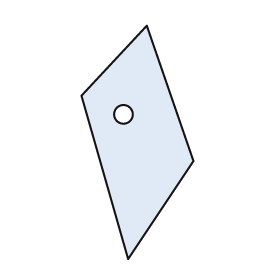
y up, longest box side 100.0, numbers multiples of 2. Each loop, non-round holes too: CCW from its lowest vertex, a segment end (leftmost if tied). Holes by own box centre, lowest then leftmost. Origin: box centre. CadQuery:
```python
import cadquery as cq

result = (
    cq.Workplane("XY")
    .moveTo(-4.0, -50.0)
    .lineTo(24.0, -8.0)
    .lineTo(4.0, 50.0)
    .lineTo(-24.0, 20.0)
    .close()
    .moveTo(-6.0, 12.0)
    .circle(4.0)
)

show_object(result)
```